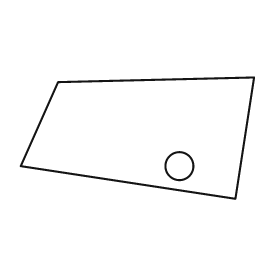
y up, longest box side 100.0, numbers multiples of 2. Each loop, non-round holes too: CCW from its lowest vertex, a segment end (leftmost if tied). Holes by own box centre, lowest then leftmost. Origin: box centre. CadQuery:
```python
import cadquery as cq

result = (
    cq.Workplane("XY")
    .moveTo(42.0, -26.0)
    .lineTo(50.0, 26.0)
    .lineTo(-34.0, 24.0)
    .lineTo(-50.0, -12.0)
    .close()
    .moveTo(18.0, -12.0)
    .circle(6.0)
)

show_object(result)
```